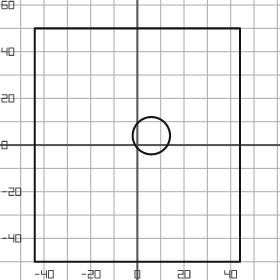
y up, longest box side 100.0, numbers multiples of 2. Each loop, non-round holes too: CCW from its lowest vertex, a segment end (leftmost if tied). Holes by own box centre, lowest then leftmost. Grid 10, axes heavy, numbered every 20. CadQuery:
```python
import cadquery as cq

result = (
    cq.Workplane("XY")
    .moveTo(-44.0, -50.0)
    .lineTo(44.0, -50.0)
    .lineTo(44.0, 50.0)
    .lineTo(-44.0, 50.0)
    .close()
    .moveTo(6.0, 4.0)
    .circle(8.0)
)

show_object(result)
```